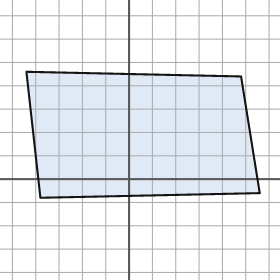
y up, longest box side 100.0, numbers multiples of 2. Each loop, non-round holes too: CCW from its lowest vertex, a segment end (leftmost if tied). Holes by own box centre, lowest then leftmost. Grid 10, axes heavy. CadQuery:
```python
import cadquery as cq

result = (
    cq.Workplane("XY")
    .moveTo(-38.0, -8.0)
    .lineTo(56.0, -6.0)
    .lineTo(48.0, 44.0)
    .lineTo(-44.0, 46.0)
    .close()
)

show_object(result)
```